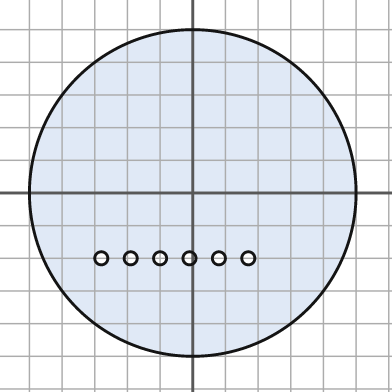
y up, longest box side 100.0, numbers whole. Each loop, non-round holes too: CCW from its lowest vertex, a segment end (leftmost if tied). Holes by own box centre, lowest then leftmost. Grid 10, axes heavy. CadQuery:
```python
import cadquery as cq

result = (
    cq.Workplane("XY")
    .moveTo(0.0, 0.0)
    .circle(50.0)
    .moveTo(-28.0, -20.0)
    .circle(2.0)
    .moveTo(-19.0, -20.0)
    .circle(2.0)
    .moveTo(-10.0, -20.0)
    .circle(2.0)
    .moveTo(-1.0, -20.0)
    .circle(2.0)
    .moveTo(8.0, -20.0)
    .circle(2.0)
    .moveTo(17.0, -20.0)
    .circle(2.0)
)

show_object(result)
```